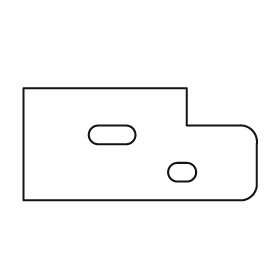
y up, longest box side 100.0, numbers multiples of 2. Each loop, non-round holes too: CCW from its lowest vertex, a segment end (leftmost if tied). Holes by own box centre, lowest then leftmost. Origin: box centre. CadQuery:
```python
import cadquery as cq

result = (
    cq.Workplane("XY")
    .moveTo(-50.0, -24.0)
    .lineTo(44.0, -24.0)
    .threePointArc((48.0, -22.0), (50.0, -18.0))
    .lineTo(50.0, 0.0)
    .threePointArc((48.0, 6.0), (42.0, 8.0))
    .lineTo(20.0, 8.0)
    .lineTo(20.0, 24.0)
    .lineTo(-50.0, 24.0)
    .close()
    .moveTo(16.0, -16.0)
    .lineTo(20.0, -16.0)
    .threePointArc((24.0, -12.0), (20.0, -8.0))
    .lineTo(16.0, -8.0)
    .threePointArc((12.0, -12.0), (16.0, -16.0))
    .close()
    .moveTo(-18.0, 0.0)
    .lineTo(-6.0, 0.0)
    .threePointArc((-2.0, 4.0), (-6.0, 8.0))
    .lineTo(-18.0, 8.0)
    .threePointArc((-22.0, 4.0), (-18.0, 0.0))
    .close()
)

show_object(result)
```